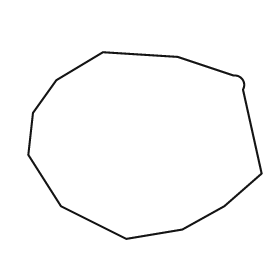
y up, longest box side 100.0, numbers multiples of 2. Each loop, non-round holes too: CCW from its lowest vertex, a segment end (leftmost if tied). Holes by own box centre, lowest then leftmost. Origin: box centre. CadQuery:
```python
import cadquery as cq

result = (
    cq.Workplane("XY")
    .moveTo(-8.0, -40.0)
    .lineTo(16.0, -36.0)
    .lineTo(34.0, -26.0)
    .lineTo(50.0, -12.0)
    .lineTo(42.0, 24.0)
    .threePointArc((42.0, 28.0), (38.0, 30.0))
    .lineTo(14.0, 38.0)
    .lineTo(-18.0, 40.0)
    .lineTo(-38.0, 28.0)
    .lineTo(-48.0, 14.0)
    .lineTo(-50.0, -4.0)
    .lineTo(-36.0, -26.0)
    .close()
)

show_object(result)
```